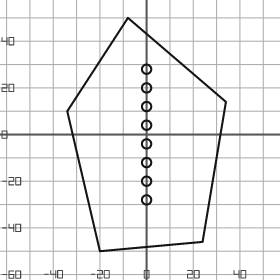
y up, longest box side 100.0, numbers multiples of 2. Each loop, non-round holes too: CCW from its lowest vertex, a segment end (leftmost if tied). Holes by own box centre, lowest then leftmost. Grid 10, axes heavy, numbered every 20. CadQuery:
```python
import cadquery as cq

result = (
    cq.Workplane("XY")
    .moveTo(-20.0, -50.0)
    .lineTo(24.0, -46.0)
    .lineTo(34.0, 14.0)
    .lineTo(-8.0, 50.0)
    .lineTo(-34.0, 10.0)
    .close()
    .moveTo(0.0, -28.0)
    .circle(2.0)
    .moveTo(0.0, -20.0)
    .circle(2.0)
    .moveTo(0.0, -12.0)
    .circle(2.0)
    .moveTo(0.0, -4.0)
    .circle(2.0)
    .moveTo(0.0, 4.0)
    .circle(2.0)
    .moveTo(0.0, 12.0)
    .circle(2.0)
    .moveTo(0.0, 20.0)
    .circle(2.0)
    .moveTo(0.0, 28.0)
    .circle(2.0)
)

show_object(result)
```